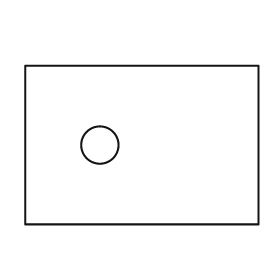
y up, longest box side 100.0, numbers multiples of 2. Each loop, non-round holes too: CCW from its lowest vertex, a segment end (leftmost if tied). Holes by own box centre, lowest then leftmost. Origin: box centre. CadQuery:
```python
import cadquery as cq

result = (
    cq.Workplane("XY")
    .moveTo(-50.0, -34.0)
    .lineTo(50.0, -34.0)
    .lineTo(50.0, 34.0)
    .lineTo(-50.0, 34.0)
    .close()
    .moveTo(-18.0, 0.0)
    .circle(8.0)
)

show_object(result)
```